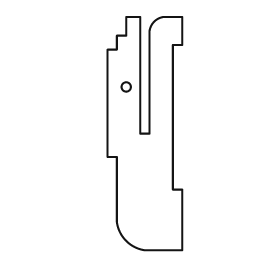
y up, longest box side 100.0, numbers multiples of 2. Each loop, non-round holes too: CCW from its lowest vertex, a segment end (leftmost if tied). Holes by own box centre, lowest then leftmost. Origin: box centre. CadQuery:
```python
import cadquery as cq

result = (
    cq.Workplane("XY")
    .moveTo(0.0, -50.0)
    .lineTo(16.0, -50.0)
    .lineTo(16.0, -24.0)
    .lineTo(12.0, -24.0)
    .lineTo(12.0, 38.0)
    .lineTo(16.0, 38.0)
    .lineTo(16.0, 50.0)
    .lineTo(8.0, 50.0)
    .threePointArc((4.0, 48.0), (2.0, 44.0))
    .lineTo(2.0, 0.0)
    .lineTo(-2.0, 0.0)
    .lineTo(-2.0, 50.0)
    .lineTo(-8.0, 50.0)
    .lineTo(-8.0, 42.0)
    .lineTo(-12.0, 42.0)
    .lineTo(-12.0, 36.0)
    .lineTo(-16.0, 36.0)
    .lineTo(-16.0, -10.0)
    .lineTo(-12.0, -10.0)
    .lineTo(-12.0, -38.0)
    .threePointArc((-8.0, -46.0), (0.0, -50.0))
    .close()
    .moveTo(-8.0, 20.0)
    .circle(2.0)
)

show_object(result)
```